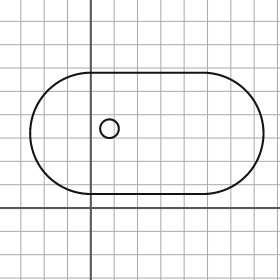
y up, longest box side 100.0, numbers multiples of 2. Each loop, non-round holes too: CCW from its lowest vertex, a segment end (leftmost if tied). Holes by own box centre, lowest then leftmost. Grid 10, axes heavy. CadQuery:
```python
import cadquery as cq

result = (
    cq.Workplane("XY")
    .moveTo(0.0, 6.0)
    .lineTo(48.0, 6.0)
    .threePointArc((74.0, 32.0), (48.0, 58.0))
    .lineTo(0.0, 58.0)
    .threePointArc((-26.0, 32.0), (0.0, 6.0))
    .close()
    .moveTo(8.0, 34.0)
    .circle(4.0)
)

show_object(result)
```